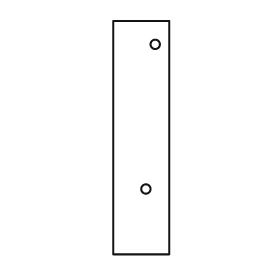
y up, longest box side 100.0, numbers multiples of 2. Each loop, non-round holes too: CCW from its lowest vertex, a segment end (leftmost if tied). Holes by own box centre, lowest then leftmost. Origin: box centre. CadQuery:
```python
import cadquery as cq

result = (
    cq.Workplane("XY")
    .moveTo(-12.0, -50.0)
    .lineTo(12.0, -50.0)
    .lineTo(12.0, 50.0)
    .lineTo(-12.0, 50.0)
    .close()
    .moveTo(2.0, -22.0)
    .circle(2.0)
    .moveTo(6.0, 40.0)
    .circle(2.0)
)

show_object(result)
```